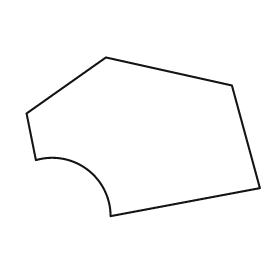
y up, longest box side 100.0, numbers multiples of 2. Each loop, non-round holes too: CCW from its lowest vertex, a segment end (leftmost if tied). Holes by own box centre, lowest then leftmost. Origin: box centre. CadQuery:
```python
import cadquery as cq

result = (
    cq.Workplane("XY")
    .moveTo(-14.0, -34.0)
    .lineTo(50.0, -22.0)
    .lineTo(38.0, 22.0)
    .lineTo(-16.0, 34.0)
    .lineTo(-50.0, 10.0)
    .lineTo(-46.0, -10.0)
    .threePointArc((-24.0, -14.0), (-14.0, -34.0))
    .close()
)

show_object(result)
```